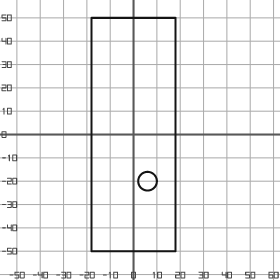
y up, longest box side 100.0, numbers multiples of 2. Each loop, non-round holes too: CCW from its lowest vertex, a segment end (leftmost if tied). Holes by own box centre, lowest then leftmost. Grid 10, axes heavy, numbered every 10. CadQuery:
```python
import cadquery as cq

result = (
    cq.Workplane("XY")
    .moveTo(-18.0, -50.0)
    .lineTo(18.0, -50.0)
    .lineTo(18.0, 50.0)
    .lineTo(-18.0, 50.0)
    .close()
    .moveTo(6.0, -20.0)
    .circle(4.0)
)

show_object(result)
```